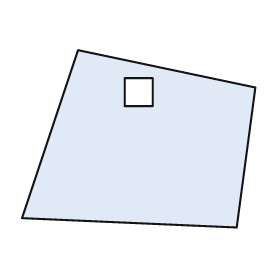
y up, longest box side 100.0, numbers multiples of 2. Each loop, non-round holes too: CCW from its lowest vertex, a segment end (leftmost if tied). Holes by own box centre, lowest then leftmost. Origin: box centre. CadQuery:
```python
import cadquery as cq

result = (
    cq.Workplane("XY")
    .moveTo(42.0, -38.0)
    .lineTo(50.0, 22.0)
    .lineTo(-26.0, 38.0)
    .lineTo(-50.0, -34.0)
    .close()
    .moveTo(-6.0, 14.0)
    .lineTo(6.0, 14.0)
    .lineTo(6.0, 26.0)
    .lineTo(-6.0, 26.0)
    .close()
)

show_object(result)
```